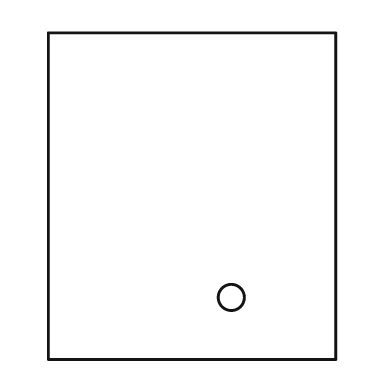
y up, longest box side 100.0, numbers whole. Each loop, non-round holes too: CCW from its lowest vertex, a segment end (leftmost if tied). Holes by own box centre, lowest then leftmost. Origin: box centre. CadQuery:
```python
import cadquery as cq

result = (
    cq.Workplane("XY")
    .moveTo(-44.0, -50.0)
    .lineTo(44.0, -50.0)
    .lineTo(44.0, 50.0)
    .lineTo(-44.0, 50.0)
    .close()
    .moveTo(12.0, -31.0)
    .circle(4.0)
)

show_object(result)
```